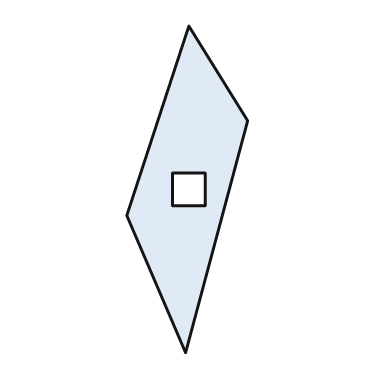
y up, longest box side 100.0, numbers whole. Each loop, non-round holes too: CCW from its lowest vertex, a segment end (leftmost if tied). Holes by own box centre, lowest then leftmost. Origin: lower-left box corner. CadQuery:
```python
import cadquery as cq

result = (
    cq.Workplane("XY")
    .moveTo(18.0, 0.0)
    .lineTo(37.0, 71.0)
    .lineTo(19.0, 100.0)
    .lineTo(0.0, 42.0)
    .close()
    .moveTo(14.0, 45.0)
    .lineTo(24.0, 45.0)
    .lineTo(24.0, 55.0)
    .lineTo(14.0, 55.0)
    .close()
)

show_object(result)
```